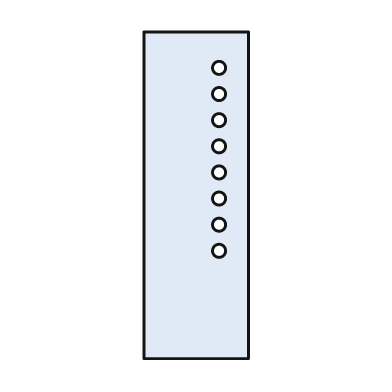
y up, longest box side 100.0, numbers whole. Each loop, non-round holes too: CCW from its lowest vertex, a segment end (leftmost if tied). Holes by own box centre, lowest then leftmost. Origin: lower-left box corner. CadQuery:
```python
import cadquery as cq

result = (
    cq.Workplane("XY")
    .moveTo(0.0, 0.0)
    .lineTo(32.0, 0.0)
    .lineTo(32.0, 100.0)
    .lineTo(0.0, 100.0)
    .close()
    .moveTo(23.0, 33.0)
    .circle(2.0)
    .moveTo(23.0, 41.0)
    .circle(2.0)
    .moveTo(23.0, 49.0)
    .circle(2.0)
    .moveTo(23.0, 57.0)
    .circle(2.0)
    .moveTo(23.0, 65.0)
    .circle(2.0)
    .moveTo(23.0, 73.0)
    .circle(2.0)
    .moveTo(23.0, 81.0)
    .circle(2.0)
    .moveTo(23.0, 89.0)
    .circle(2.0)
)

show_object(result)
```